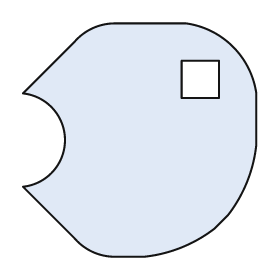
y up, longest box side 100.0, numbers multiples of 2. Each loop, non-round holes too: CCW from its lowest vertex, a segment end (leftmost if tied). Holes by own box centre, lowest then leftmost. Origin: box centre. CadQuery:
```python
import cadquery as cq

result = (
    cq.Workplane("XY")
    .moveTo(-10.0, -50.0)
    .lineTo(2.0, -50.0)
    .threePointArc((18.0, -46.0), (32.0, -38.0))
    .lineTo(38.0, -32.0)
    .threePointArc((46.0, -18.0), (50.0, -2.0))
    .lineTo(50.0, 20.0)
    .threePointArc((40.0, 40.0), (20.0, 50.0))
    .lineTo(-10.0, 50.0)
    .threePointArc((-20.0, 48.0), (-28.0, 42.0))
    .lineTo(-50.0, 20.0)
    .threePointArc((-32.0, 0.0), (-50.0, -20.0))
    .lineTo(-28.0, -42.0)
    .threePointArc((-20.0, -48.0), (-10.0, -50.0))
    .close()
    .moveTo(18.0, 18.0)
    .lineTo(34.0, 18.0)
    .lineTo(34.0, 34.0)
    .lineTo(18.0, 34.0)
    .close()
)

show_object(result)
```